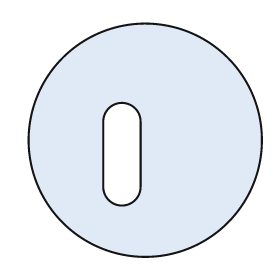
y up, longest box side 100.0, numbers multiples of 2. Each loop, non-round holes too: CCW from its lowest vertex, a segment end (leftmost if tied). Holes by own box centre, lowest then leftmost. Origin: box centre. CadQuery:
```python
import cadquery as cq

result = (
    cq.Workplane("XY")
    .moveTo(0.0, 0.0)
    .circle(50.0)
    .moveTo(-18.0, -20.0)
    .threePointArc((-10.0, -28.0), (-2.0, -20.0))
    .lineTo(-2.0, 8.0)
    .threePointArc((-10.0, 16.0), (-18.0, 8.0))
    .close()
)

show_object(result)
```